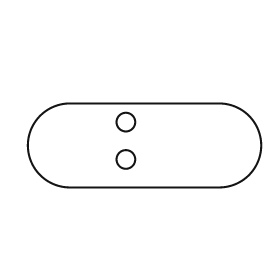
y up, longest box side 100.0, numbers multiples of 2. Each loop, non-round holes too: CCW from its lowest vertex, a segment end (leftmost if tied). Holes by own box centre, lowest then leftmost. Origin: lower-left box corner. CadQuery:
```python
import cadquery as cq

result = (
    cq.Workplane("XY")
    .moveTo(18.0, 0.0)
    .lineTo(82.0, 0.0)
    .threePointArc((100.0, 18.0), (82.0, 36.0))
    .lineTo(18.0, 36.0)
    .threePointArc((0.0, 18.0), (18.0, 0.0))
    .close()
    .moveTo(42.0, 12.0)
    .circle(4.0)
    .moveTo(42.0, 28.0)
    .circle(4.0)
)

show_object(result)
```